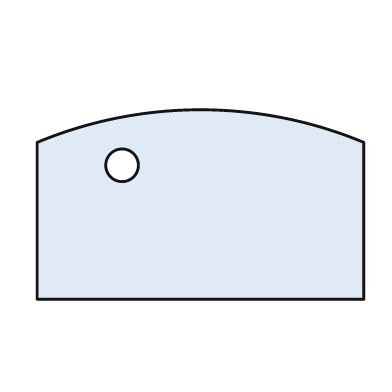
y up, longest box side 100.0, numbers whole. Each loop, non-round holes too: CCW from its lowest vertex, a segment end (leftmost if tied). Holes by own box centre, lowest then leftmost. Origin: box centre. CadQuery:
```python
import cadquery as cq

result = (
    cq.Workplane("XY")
    .moveTo(-50.0, -29.0)
    .lineTo(50.0, -29.0)
    .lineTo(50.0, 19.0)
    .threePointArc((0.0, 29.0), (-50.0, 19.0))
    .close()
    .moveTo(-24.0, 12.0)
    .circle(5.0)
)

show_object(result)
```